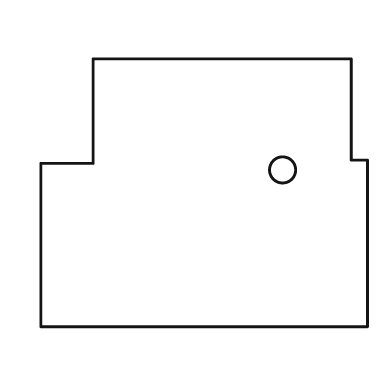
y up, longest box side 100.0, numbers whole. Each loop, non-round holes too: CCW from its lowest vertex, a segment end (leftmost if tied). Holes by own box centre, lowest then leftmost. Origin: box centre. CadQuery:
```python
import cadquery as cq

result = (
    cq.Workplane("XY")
    .moveTo(-50.0, -41.0)
    .lineTo(50.0, -41.0)
    .lineTo(50.0, 10.0)
    .lineTo(45.0, 10.0)
    .lineTo(45.0, 41.0)
    .lineTo(-34.0, 41.0)
    .lineTo(-34.0, 9.0)
    .lineTo(-50.0, 9.0)
    .close()
    .moveTo(24.0, 7.0)
    .circle(4.0)
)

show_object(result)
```